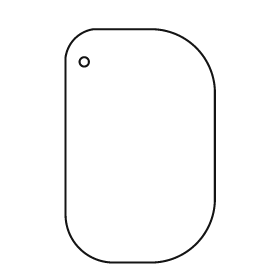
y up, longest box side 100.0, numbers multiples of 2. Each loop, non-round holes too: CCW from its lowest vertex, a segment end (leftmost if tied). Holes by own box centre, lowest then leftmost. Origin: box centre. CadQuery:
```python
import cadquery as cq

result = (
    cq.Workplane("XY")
    .moveTo(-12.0, -50.0)
    .lineTo(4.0, -50.0)
    .threePointArc((24.0, -42.0), (32.0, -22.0))
    .lineTo(32.0, 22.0)
    .threePointArc((24.0, 42.0), (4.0, 50.0))
    .lineTo(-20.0, 50.0)
    .threePointArc((-28.0, 46.0), (-32.0, 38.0))
    .lineTo(-32.0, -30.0)
    .threePointArc((-26.0, -44.0), (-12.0, -50.0))
    .close()
    .moveTo(-24.0, 36.0)
    .circle(2.0)
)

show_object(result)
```